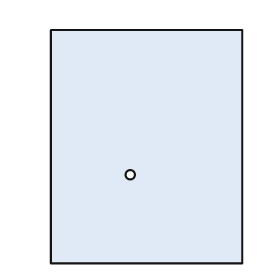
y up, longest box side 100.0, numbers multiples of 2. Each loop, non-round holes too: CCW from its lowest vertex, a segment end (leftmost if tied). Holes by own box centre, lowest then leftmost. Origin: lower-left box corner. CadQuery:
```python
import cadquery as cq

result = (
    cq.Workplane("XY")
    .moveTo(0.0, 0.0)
    .lineTo(82.0, 0.0)
    .lineTo(82.0, 100.0)
    .lineTo(0.0, 100.0)
    .close()
    .moveTo(34.0, 38.0)
    .circle(2.0)
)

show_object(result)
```